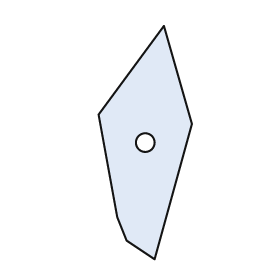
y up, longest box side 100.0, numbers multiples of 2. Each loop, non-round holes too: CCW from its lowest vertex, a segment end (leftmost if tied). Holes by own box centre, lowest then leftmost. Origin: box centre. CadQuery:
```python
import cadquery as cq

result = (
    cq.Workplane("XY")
    .moveTo(4.0, -50.0)
    .lineTo(20.0, 8.0)
    .lineTo(8.0, 50.0)
    .lineTo(-20.0, 12.0)
    .lineTo(-12.0, -32.0)
    .lineTo(-8.0, -42.0)
    .close()
    .moveTo(0.0, 0.0)
    .circle(4.0)
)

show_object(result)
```